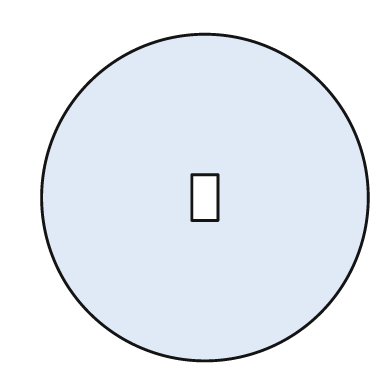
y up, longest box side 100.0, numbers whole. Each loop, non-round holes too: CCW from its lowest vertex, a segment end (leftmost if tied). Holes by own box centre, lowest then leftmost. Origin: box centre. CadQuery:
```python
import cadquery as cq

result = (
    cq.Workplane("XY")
    .moveTo(0.0, 0.0)
    .circle(50.0)
    .moveTo(-4.0, -7.0)
    .lineTo(4.0, -7.0)
    .lineTo(4.0, 7.0)
    .lineTo(-4.0, 7.0)
    .close()
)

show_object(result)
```